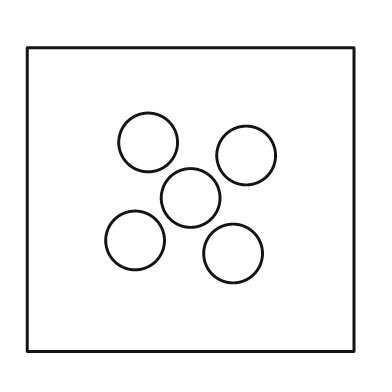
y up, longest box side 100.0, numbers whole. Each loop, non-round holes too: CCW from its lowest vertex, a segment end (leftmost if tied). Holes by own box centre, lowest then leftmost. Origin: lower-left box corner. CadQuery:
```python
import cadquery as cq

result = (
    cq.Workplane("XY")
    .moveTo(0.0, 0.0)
    .lineTo(100.0, 0.0)
    .lineTo(100.0, 93.0)
    .lineTo(0.0, 93.0)
    .close()
    .moveTo(63.0, 30.0)
    .circle(9.0)
    .moveTo(33.0, 34.0)
    .circle(9.0)
    .moveTo(50.0, 47.0)
    .circle(9.0)
    .moveTo(67.0, 60.0)
    .circle(9.0)
    .moveTo(37.0, 64.0)
    .circle(9.0)
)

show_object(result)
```